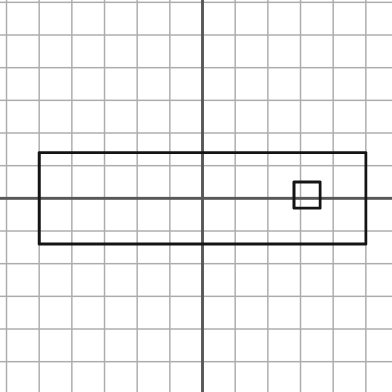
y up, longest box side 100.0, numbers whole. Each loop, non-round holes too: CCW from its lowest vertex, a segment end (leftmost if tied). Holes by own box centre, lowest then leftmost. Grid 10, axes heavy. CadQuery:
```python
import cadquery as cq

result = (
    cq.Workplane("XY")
    .moveTo(-50.0, -14.0)
    .lineTo(50.0, -14.0)
    .lineTo(50.0, 14.0)
    .lineTo(-50.0, 14.0)
    .close()
    .moveTo(28.0, -3.0)
    .lineTo(36.0, -3.0)
    .lineTo(36.0, 5.0)
    .lineTo(28.0, 5.0)
    .close()
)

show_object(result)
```